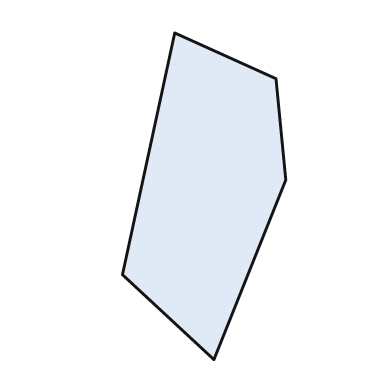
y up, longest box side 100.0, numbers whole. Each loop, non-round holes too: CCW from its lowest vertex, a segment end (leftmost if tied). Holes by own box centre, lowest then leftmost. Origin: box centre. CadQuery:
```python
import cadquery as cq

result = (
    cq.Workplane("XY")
    .moveTo(3.0, -50.0)
    .lineTo(25.0, 5.0)
    .lineTo(22.0, 36.0)
    .lineTo(-9.0, 50.0)
    .lineTo(-25.0, -24.0)
    .close()
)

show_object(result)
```